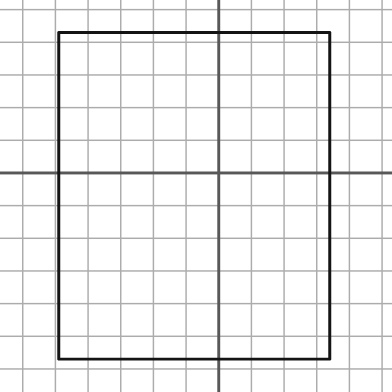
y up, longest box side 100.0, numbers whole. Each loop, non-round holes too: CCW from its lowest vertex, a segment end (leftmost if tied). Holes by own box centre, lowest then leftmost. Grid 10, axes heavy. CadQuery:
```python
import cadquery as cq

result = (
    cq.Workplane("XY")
    .moveTo(-49.0, -57.0)
    .lineTo(34.0, -57.0)
    .lineTo(34.0, 43.0)
    .lineTo(-49.0, 43.0)
    .close()
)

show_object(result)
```